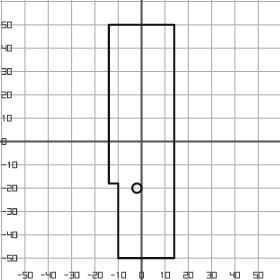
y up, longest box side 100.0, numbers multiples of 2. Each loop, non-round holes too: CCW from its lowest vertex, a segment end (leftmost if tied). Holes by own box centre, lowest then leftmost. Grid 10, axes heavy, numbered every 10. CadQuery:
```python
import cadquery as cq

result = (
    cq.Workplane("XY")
    .moveTo(-10.0, -50.0)
    .lineTo(14.0, -50.0)
    .lineTo(14.0, 50.0)
    .lineTo(-14.0, 50.0)
    .lineTo(-14.0, -18.0)
    .lineTo(-10.0, -18.0)
    .close()
    .moveTo(-2.0, -20.0)
    .circle(2.0)
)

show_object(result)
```